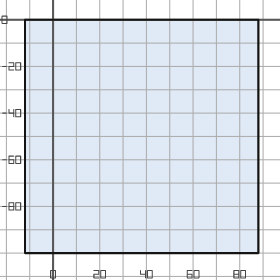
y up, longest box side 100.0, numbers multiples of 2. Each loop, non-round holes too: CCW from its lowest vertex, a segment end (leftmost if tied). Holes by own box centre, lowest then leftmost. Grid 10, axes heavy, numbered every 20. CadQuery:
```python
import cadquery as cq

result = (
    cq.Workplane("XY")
    .moveTo(-12.0, -100.0)
    .lineTo(88.0, -100.0)
    .lineTo(88.0, 0.0)
    .lineTo(-12.0, 0.0)
    .close()
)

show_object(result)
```